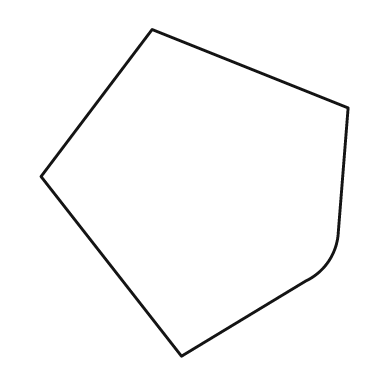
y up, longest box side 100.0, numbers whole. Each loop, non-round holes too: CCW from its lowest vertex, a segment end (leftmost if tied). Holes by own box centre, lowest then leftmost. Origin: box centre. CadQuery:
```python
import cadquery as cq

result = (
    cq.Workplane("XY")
    .moveTo(-4.0, -50.0)
    .lineTo(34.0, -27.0)
    .threePointArc((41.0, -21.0), (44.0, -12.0))
    .lineTo(47.0, 26.0)
    .lineTo(-13.0, 50.0)
    .lineTo(-47.0, 5.0)
    .close()
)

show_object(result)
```